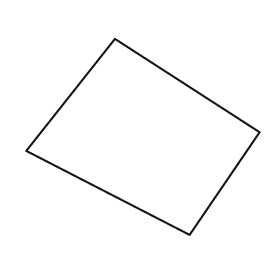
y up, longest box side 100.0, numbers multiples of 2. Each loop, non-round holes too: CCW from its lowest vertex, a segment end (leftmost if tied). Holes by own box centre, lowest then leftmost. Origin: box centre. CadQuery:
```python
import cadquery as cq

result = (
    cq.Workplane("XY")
    .moveTo(20.0, -42.0)
    .lineTo(50.0, 2.0)
    .lineTo(-12.0, 42.0)
    .lineTo(-50.0, -6.0)
    .close()
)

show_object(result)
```